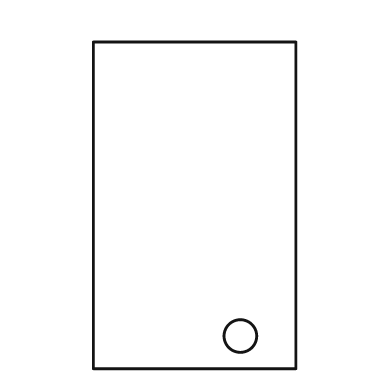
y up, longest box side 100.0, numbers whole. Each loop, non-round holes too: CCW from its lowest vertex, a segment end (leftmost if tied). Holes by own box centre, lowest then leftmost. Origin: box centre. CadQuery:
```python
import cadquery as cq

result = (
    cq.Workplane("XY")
    .moveTo(-31.0, -50.0)
    .lineTo(31.0, -50.0)
    .lineTo(31.0, 50.0)
    .lineTo(-31.0, 50.0)
    .close()
    .moveTo(14.0, -40.0)
    .circle(5.0)
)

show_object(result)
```